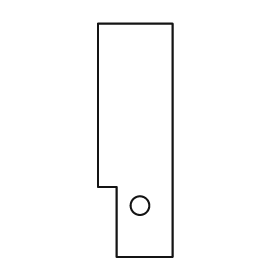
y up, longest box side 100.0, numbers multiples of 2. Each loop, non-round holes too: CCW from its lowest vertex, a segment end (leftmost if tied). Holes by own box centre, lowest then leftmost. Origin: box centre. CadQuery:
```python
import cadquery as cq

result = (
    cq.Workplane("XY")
    .moveTo(-8.0, -50.0)
    .lineTo(16.0, -50.0)
    .lineTo(16.0, 50.0)
    .lineTo(-16.0, 50.0)
    .lineTo(-16.0, -20.0)
    .lineTo(-8.0, -20.0)
    .close()
    .moveTo(2.0, -28.0)
    .circle(4.0)
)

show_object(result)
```